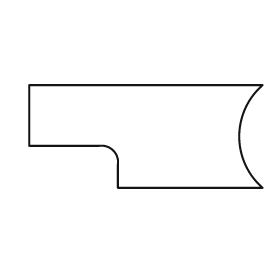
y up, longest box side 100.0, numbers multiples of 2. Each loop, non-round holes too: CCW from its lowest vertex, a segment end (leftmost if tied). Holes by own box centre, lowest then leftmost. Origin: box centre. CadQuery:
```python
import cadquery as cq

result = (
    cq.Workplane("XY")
    .moveTo(-12.0, -22.0)
    .lineTo(50.0, -22.0)
    .threePointArc((40.0, 0.0), (50.0, 22.0))
    .lineTo(-50.0, 22.0)
    .lineTo(-50.0, -4.0)
    .lineTo(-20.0, -4.0)
    .threePointArc((-14.0, -6.0), (-12.0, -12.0))
    .close()
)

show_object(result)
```